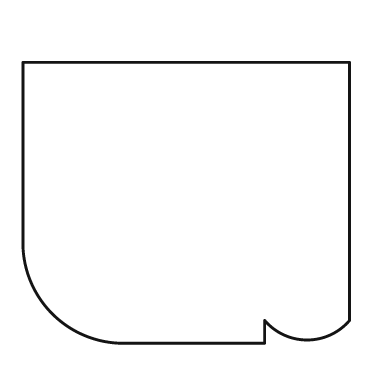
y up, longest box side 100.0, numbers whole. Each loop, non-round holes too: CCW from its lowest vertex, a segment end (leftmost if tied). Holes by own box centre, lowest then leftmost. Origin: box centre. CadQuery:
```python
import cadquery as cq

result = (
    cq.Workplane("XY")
    .moveTo(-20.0, -43.0)
    .lineTo(24.0, -43.0)
    .lineTo(24.0, -36.0)
    .threePointArc((37.0, -42.0), (50.0, -36.0))
    .lineTo(50.0, 43.0)
    .lineTo(-50.0, 43.0)
    .lineTo(-50.0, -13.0)
    .threePointArc((-41.0, -34.0), (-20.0, -43.0))
    .close()
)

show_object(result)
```